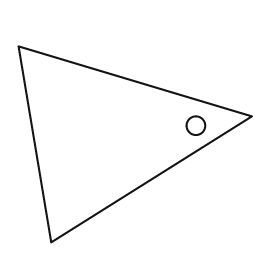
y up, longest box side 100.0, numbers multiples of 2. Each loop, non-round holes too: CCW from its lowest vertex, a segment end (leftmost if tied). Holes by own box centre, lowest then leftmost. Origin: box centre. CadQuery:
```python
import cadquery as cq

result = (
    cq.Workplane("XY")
    .moveTo(-36.0, -42.0)
    .lineTo(50.0, 12.0)
    .lineTo(-50.0, 42.0)
    .close()
    .moveTo(26.0, 8.0)
    .circle(4.0)
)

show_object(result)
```